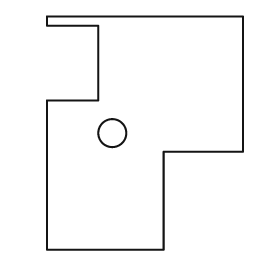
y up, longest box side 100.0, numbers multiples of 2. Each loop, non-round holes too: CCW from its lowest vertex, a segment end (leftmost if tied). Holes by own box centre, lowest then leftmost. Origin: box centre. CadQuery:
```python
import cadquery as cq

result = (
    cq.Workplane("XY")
    .moveTo(-42.0, -50.0)
    .lineTo(8.0, -50.0)
    .lineTo(8.0, -8.0)
    .lineTo(42.0, -8.0)
    .lineTo(42.0, 50.0)
    .lineTo(-42.0, 50.0)
    .lineTo(-42.0, 46.0)
    .lineTo(-20.0, 46.0)
    .lineTo(-20.0, 14.0)
    .lineTo(-42.0, 14.0)
    .close()
    .moveTo(-14.0, 0.0)
    .circle(6.0)
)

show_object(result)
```